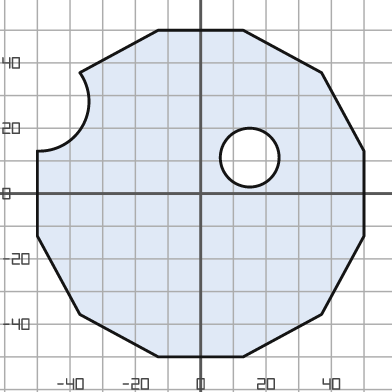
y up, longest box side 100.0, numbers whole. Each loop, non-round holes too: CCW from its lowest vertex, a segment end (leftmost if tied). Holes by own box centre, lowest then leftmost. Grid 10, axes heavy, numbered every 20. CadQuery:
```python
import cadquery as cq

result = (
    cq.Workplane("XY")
    .moveTo(-13.0, -50.0)
    .lineTo(13.0, -50.0)
    .lineTo(37.0, -37.0)
    .lineTo(50.0, -13.0)
    .lineTo(50.0, 13.0)
    .lineTo(37.0, 37.0)
    .lineTo(13.0, 50.0)
    .lineTo(-13.0, 50.0)
    .lineTo(-37.0, 37.0)
    .threePointArc((-36.0, 21.0), (-50.0, 13.0))
    .lineTo(-50.0, -13.0)
    .lineTo(-37.0, -37.0)
    .close()
    .moveTo(15.0, 11.0)
    .circle(9.0)
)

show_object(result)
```